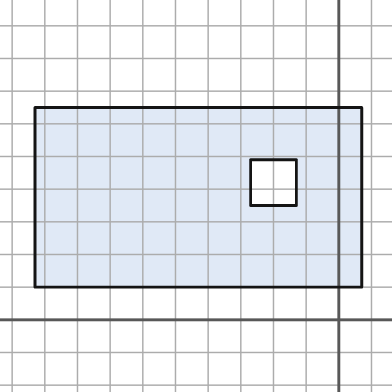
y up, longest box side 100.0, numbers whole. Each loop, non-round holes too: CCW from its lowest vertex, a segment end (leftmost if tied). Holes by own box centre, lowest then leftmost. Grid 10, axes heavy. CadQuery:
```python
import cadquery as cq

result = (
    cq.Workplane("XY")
    .moveTo(-93.0, 10.0)
    .lineTo(7.0, 10.0)
    .lineTo(7.0, 65.0)
    .lineTo(-93.0, 65.0)
    .close()
    .moveTo(-27.0, 35.0)
    .lineTo(-13.0, 35.0)
    .lineTo(-13.0, 49.0)
    .lineTo(-27.0, 49.0)
    .close()
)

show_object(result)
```